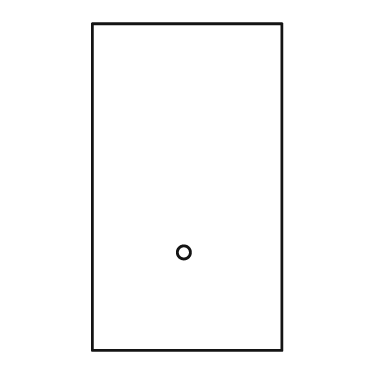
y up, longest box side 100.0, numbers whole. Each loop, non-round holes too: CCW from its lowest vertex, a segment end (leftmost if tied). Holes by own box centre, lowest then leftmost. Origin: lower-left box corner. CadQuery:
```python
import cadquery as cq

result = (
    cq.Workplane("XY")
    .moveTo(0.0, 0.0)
    .lineTo(58.0, 0.0)
    .lineTo(58.0, 100.0)
    .lineTo(0.0, 100.0)
    .close()
    .moveTo(28.0, 30.0)
    .circle(2.0)
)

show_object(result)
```